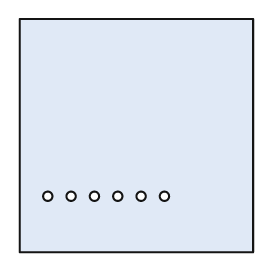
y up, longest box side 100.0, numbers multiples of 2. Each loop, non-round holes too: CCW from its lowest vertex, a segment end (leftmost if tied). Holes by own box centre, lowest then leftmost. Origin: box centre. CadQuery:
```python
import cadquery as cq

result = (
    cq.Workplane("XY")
    .moveTo(-50.0, -50.0)
    .lineTo(50.0, -50.0)
    .lineTo(50.0, 50.0)
    .lineTo(-50.0, 50.0)
    .close()
    .moveTo(-38.0, -26.0)
    .circle(2.0)
    .moveTo(-28.0, -26.0)
    .circle(2.0)
    .moveTo(-18.0, -26.0)
    .circle(2.0)
    .moveTo(-8.0, -26.0)
    .circle(2.0)
    .moveTo(2.0, -26.0)
    .circle(2.0)
    .moveTo(12.0, -26.0)
    .circle(2.0)
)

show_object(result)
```